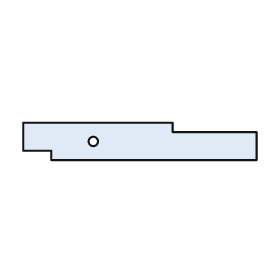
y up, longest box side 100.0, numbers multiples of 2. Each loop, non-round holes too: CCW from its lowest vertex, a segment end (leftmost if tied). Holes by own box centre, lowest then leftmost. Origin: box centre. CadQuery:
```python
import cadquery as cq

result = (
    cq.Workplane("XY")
    .moveTo(-38.0, -8.0)
    .lineTo(50.0, -8.0)
    .lineTo(50.0, 4.0)
    .lineTo(14.0, 4.0)
    .lineTo(14.0, 8.0)
    .lineTo(-50.0, 8.0)
    .lineTo(-50.0, -4.0)
    .lineTo(-38.0, -4.0)
    .close()
    .moveTo(-20.0, 0.0)
    .circle(2.0)
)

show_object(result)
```